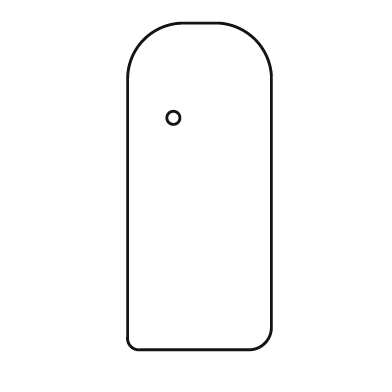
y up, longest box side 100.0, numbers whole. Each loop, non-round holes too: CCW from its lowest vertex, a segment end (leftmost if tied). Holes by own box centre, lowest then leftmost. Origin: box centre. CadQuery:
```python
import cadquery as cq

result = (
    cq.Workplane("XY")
    .moveTo(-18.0, -50.0)
    .lineTo(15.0, -50.0)
    .threePointArc((20.0, -48.0), (22.0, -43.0))
    .lineTo(22.0, 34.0)
    .threePointArc((17.0, 45.0), (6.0, 50.0))
    .lineTo(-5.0, 50.0)
    .threePointArc((-17.0, 45.0), (-22.0, 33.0))
    .lineTo(-22.0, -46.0)
    .threePointArc((-21.0, -49.0), (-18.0, -50.0))
    .close()
    .moveTo(-8.0, 21.0)
    .circle(2.0)
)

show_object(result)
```